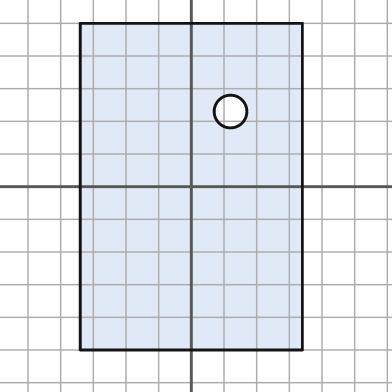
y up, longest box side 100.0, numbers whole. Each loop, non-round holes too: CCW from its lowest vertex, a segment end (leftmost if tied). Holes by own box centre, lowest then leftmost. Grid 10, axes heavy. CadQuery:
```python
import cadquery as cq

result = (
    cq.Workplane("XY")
    .moveTo(-34.0, -50.0)
    .lineTo(34.0, -50.0)
    .lineTo(34.0, 50.0)
    .lineTo(-34.0, 50.0)
    .close()
    .moveTo(12.0, 23.0)
    .circle(5.0)
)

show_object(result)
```